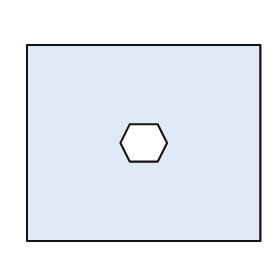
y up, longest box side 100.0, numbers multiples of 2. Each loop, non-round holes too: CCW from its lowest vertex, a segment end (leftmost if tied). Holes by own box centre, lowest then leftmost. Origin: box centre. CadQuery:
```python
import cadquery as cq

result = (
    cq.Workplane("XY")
    .moveTo(-50.0, -42.0)
    .lineTo(50.0, -42.0)
    .lineTo(50.0, 42.0)
    .lineTo(-50.0, 42.0)
    .close()
    .moveTo(-6.0, -8.0)
    .lineTo(6.0, -8.0)
    .lineTo(10.0, 0.0)
    .lineTo(6.0, 8.0)
    .lineTo(-6.0, 8.0)
    .lineTo(-10.0, 0.0)
    .close()
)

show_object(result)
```